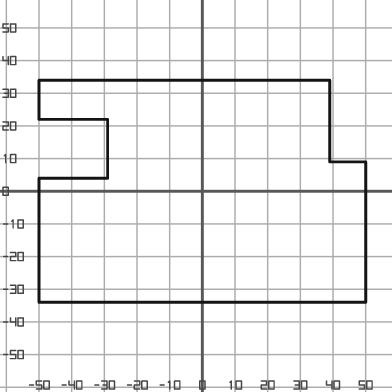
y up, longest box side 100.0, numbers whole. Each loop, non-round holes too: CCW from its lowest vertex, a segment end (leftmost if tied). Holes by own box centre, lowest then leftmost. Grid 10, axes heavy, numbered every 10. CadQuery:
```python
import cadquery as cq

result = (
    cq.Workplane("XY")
    .moveTo(-50.0, -34.0)
    .lineTo(50.0, -34.0)
    .lineTo(50.0, 9.0)
    .lineTo(39.0, 9.0)
    .lineTo(39.0, 34.0)
    .lineTo(-50.0, 34.0)
    .lineTo(-50.0, 22.0)
    .lineTo(-29.0, 22.0)
    .lineTo(-29.0, 4.0)
    .lineTo(-50.0, 4.0)
    .close()
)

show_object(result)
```